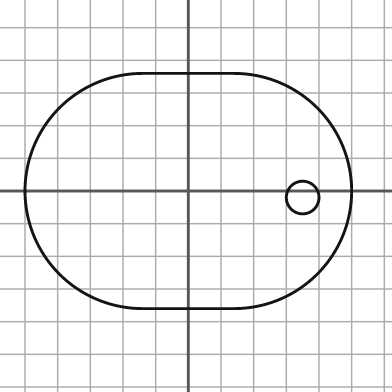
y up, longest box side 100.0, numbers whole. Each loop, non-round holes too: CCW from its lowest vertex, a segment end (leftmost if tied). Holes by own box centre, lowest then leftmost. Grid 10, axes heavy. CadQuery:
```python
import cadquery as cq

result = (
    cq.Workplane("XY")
    .moveTo(-14.0, -36.0)
    .lineTo(14.0, -36.0)
    .threePointArc((50.0, 0.0), (14.0, 36.0))
    .lineTo(-14.0, 36.0)
    .threePointArc((-50.0, 0.0), (-14.0, -36.0))
    .close()
    .moveTo(35.0, -2.0)
    .circle(5.0)
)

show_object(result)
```